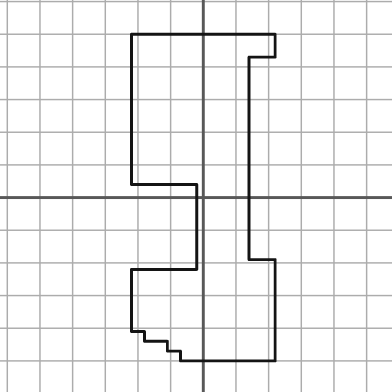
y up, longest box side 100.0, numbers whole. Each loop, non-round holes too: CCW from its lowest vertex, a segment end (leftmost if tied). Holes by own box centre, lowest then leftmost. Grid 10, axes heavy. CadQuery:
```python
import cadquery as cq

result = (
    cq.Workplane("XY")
    .moveTo(-7.0, -50.0)
    .lineTo(22.0, -50.0)
    .lineTo(22.0, -19.0)
    .lineTo(14.0, -19.0)
    .lineTo(14.0, 43.0)
    .lineTo(22.0, 43.0)
    .lineTo(22.0, 50.0)
    .lineTo(-22.0, 50.0)
    .lineTo(-22.0, 4.0)
    .lineTo(-2.0, 4.0)
    .lineTo(-2.0, -22.0)
    .lineTo(-22.0, -22.0)
    .lineTo(-22.0, -41.0)
    .lineTo(-18.0, -41.0)
    .lineTo(-18.0, -44.0)
    .lineTo(-11.0, -44.0)
    .lineTo(-11.0, -47.0)
    .lineTo(-7.0, -47.0)
    .close()
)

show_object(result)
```